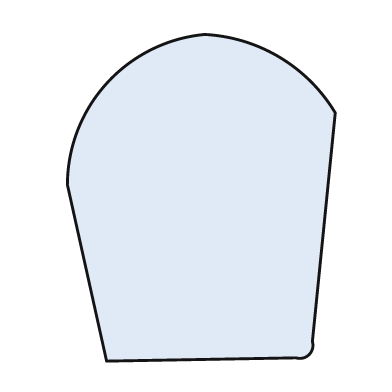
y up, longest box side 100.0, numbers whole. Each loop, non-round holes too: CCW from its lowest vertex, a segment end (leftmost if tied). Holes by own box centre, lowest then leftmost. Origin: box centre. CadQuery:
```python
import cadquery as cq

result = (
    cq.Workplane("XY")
    .moveTo(-29.0, -50.0)
    .lineTo(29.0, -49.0)
    .threePointArc((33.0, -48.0), (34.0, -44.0))
    .lineTo(41.0, 26.0)
    .threePointArc((24.0, 43.0), (1.0, 50.0))
    .threePointArc((-29.0, 35.0), (-41.0, 4.0))
    .close()
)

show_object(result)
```